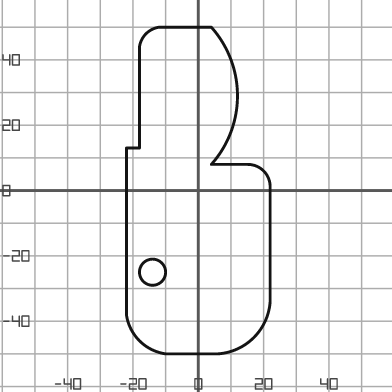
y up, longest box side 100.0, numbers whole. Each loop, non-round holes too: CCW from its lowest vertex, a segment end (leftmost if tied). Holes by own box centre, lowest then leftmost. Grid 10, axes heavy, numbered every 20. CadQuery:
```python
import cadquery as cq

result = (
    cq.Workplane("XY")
    .moveTo(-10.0, -50.0)
    .lineTo(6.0, -50.0)
    .threePointArc((17.0, -45.0), (22.0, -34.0))
    .lineTo(22.0, 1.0)
    .threePointArc((20.0, 6.0), (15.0, 8.0))
    .lineTo(4.0, 8.0)
    .threePointArc((12.0, 29.0), (4.0, 50.0))
    .lineTo(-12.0, 50.0)
    .threePointArc((-16.0, 48.0), (-18.0, 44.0))
    .lineTo(-18.0, 13.0)
    .lineTo(-22.0, 13.0)
    .lineTo(-22.0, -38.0)
    .threePointArc((-18.0, -46.0), (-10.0, -50.0))
    .close()
    .moveTo(-14.0, -25.0)
    .circle(4.0)
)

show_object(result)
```